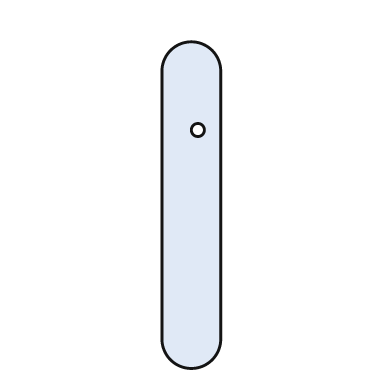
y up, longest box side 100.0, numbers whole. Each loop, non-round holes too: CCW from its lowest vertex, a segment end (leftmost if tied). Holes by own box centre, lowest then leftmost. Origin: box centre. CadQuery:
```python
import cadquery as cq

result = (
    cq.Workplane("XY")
    .moveTo(-9.0, -41.0)
    .threePointArc((0.0, -50.0), (9.0, -41.0))
    .lineTo(9.0, 41.0)
    .threePointArc((0.0, 50.0), (-9.0, 41.0))
    .close()
    .moveTo(2.0, 23.0)
    .circle(2.0)
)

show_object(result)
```